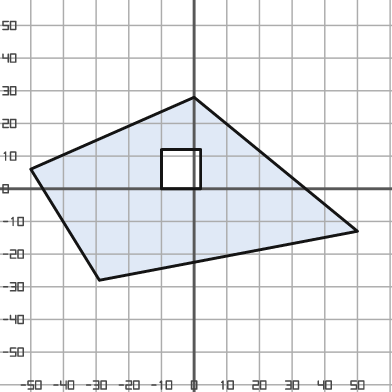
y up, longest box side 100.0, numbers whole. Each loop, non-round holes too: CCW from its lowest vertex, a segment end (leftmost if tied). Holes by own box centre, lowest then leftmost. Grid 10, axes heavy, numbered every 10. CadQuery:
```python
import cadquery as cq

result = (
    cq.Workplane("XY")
    .moveTo(-29.0, -28.0)
    .lineTo(50.0, -13.0)
    .lineTo(0.0, 28.0)
    .lineTo(-50.0, 6.0)
    .close()
    .moveTo(-10.0, 0.0)
    .lineTo(2.0, 0.0)
    .lineTo(2.0, 12.0)
    .lineTo(-10.0, 12.0)
    .close()
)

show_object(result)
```